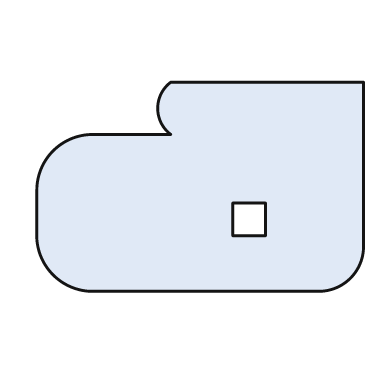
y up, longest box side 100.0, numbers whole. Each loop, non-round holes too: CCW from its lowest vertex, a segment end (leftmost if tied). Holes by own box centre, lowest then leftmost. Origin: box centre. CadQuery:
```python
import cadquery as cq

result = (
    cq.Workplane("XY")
    .moveTo(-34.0, -32.0)
    .lineTo(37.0, -32.0)
    .threePointArc((46.0, -28.0), (50.0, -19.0))
    .lineTo(50.0, 32.0)
    .lineTo(-9.0, 32.0)
    .threePointArc((-13.0, 24.0), (-9.0, 16.0))
    .lineTo(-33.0, 16.0)
    .threePointArc((-45.0, 11.0), (-50.0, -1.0))
    .lineTo(-50.0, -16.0)
    .threePointArc((-45.0, -27.0), (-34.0, -32.0))
    .close()
    .moveTo(10.0, -15.0)
    .lineTo(20.0, -15.0)
    .lineTo(20.0, -5.0)
    .lineTo(10.0, -5.0)
    .close()
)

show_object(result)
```